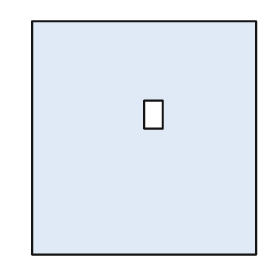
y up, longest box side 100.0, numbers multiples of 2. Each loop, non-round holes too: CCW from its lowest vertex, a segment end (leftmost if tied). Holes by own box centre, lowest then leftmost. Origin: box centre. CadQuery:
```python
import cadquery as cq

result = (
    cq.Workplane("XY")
    .moveTo(-48.0, -50.0)
    .lineTo(48.0, -50.0)
    .lineTo(48.0, 50.0)
    .lineTo(-48.0, 50.0)
    .close()
    .moveTo(0.0, 4.0)
    .lineTo(8.0, 4.0)
    .lineTo(8.0, 16.0)
    .lineTo(0.0, 16.0)
    .close()
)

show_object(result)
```